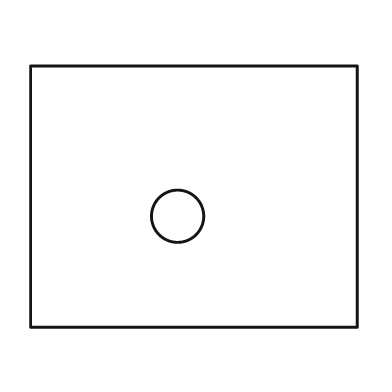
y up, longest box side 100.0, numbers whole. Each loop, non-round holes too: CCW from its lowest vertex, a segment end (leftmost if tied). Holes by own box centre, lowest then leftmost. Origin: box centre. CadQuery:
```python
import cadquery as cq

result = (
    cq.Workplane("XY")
    .moveTo(-50.0, -40.0)
    .lineTo(50.0, -40.0)
    .lineTo(50.0, 40.0)
    .lineTo(-50.0, 40.0)
    .close()
    .moveTo(-5.0, -6.0)
    .circle(8.0)
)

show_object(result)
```